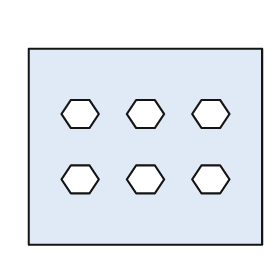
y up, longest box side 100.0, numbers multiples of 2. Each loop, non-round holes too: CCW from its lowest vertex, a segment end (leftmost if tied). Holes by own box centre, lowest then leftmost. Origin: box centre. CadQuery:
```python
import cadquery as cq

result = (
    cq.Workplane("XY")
    .moveTo(-50.0, -42.0)
    .lineTo(50.0, -42.0)
    .lineTo(50.0, 42.0)
    .lineTo(-50.0, 42.0)
    .close()
    .moveTo(-32.0, -20.0)
    .lineTo(-24.0, -20.0)
    .lineTo(-20.0, -14.0)
    .lineTo(-24.0, -8.0)
    .lineTo(-32.0, -8.0)
    .lineTo(-36.0, -14.0)
    .close()
    .moveTo(-4.0, -20.0)
    .lineTo(4.0, -20.0)
    .lineTo(8.0, -14.0)
    .lineTo(4.0, -8.0)
    .lineTo(-4.0, -8.0)
    .lineTo(-8.0, -14.0)
    .close()
    .moveTo(24.0, -20.0)
    .lineTo(32.0, -20.0)
    .lineTo(36.0, -14.0)
    .lineTo(32.0, -8.0)
    .lineTo(24.0, -8.0)
    .lineTo(20.0, -14.0)
    .close()
    .moveTo(-32.0, 8.0)
    .lineTo(-24.0, 8.0)
    .lineTo(-20.0, 14.0)
    .lineTo(-24.0, 20.0)
    .lineTo(-32.0, 20.0)
    .lineTo(-36.0, 14.0)
    .close()
    .moveTo(-4.0, 8.0)
    .lineTo(4.0, 8.0)
    .lineTo(8.0, 14.0)
    .lineTo(4.0, 20.0)
    .lineTo(-4.0, 20.0)
    .lineTo(-8.0, 14.0)
    .close()
    .moveTo(24.0, 8.0)
    .lineTo(32.0, 8.0)
    .lineTo(36.0, 14.0)
    .lineTo(32.0, 20.0)
    .lineTo(24.0, 20.0)
    .lineTo(20.0, 14.0)
    .close()
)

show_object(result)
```